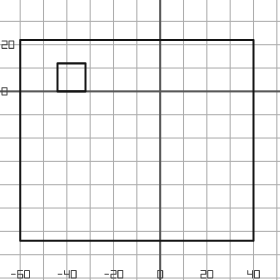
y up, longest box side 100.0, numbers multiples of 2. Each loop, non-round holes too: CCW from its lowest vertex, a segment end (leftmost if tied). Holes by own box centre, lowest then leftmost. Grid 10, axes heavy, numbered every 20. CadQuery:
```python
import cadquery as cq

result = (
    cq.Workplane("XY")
    .moveTo(-60.0, -64.0)
    .lineTo(40.0, -64.0)
    .lineTo(40.0, 22.0)
    .lineTo(-60.0, 22.0)
    .close()
    .moveTo(-44.0, 0.0)
    .lineTo(-32.0, 0.0)
    .lineTo(-32.0, 12.0)
    .lineTo(-44.0, 12.0)
    .close()
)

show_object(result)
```